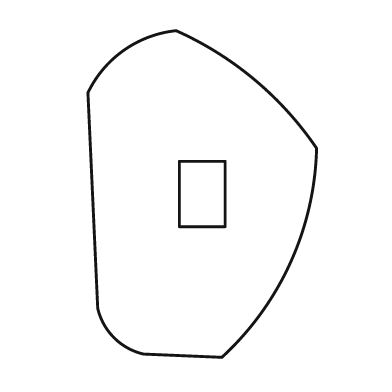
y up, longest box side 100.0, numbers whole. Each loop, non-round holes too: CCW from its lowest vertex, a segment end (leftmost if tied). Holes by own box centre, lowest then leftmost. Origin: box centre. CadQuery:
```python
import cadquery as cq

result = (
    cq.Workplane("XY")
    .moveTo(6.0, -50.0)
    .threePointArc((27.0, -21.0), (35.0, 14.0))
    .threePointArc((16.0, 35.0), (-8.0, 50.0))
    .threePointArc((-24.0, 44.0), (-35.0, 31.0))
    .lineTo(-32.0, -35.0)
    .threePointArc((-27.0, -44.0), (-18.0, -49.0))
    .close()
    .moveTo(-7.0, -10.0)
    .lineTo(7.0, -10.0)
    .lineTo(7.0, 10.0)
    .lineTo(-7.0, 10.0)
    .close()
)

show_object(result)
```